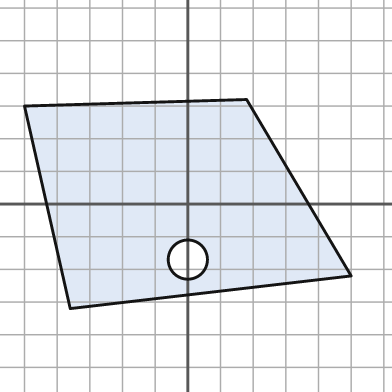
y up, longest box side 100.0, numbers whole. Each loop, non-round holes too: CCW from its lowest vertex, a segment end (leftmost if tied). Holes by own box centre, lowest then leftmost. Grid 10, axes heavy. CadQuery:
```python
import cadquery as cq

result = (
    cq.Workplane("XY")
    .moveTo(-36.0, -32.0)
    .lineTo(50.0, -22.0)
    .lineTo(18.0, 32.0)
    .lineTo(-50.0, 30.0)
    .close()
    .moveTo(0.0, -17.0)
    .circle(6.0)
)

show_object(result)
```